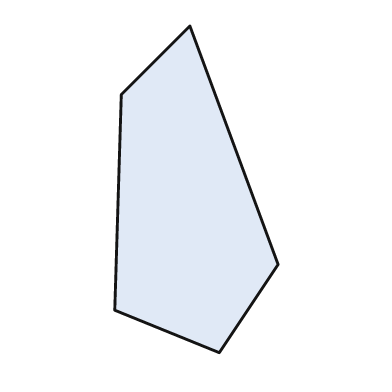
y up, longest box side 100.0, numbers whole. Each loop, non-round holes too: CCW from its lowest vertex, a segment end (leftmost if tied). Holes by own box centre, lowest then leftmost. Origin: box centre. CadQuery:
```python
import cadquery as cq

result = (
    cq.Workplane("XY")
    .moveTo(7.0, -50.0)
    .lineTo(25.0, -23.0)
    .lineTo(-2.0, 50.0)
    .lineTo(-23.0, 29.0)
    .lineTo(-25.0, -37.0)
    .close()
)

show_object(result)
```